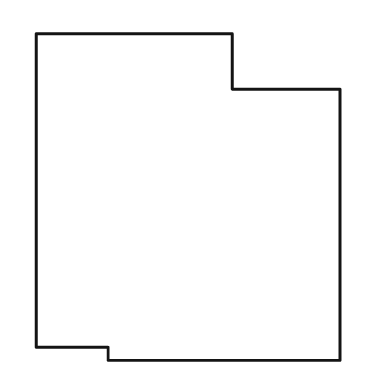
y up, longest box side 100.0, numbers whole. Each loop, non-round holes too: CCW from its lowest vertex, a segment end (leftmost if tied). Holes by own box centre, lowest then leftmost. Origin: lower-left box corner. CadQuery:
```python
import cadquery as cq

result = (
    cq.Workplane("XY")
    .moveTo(22.0, 0.0)
    .lineTo(93.0, 0.0)
    .lineTo(93.0, 83.0)
    .lineTo(60.0, 83.0)
    .lineTo(60.0, 100.0)
    .lineTo(0.0, 100.0)
    .lineTo(0.0, 4.0)
    .lineTo(22.0, 4.0)
    .close()
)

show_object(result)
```